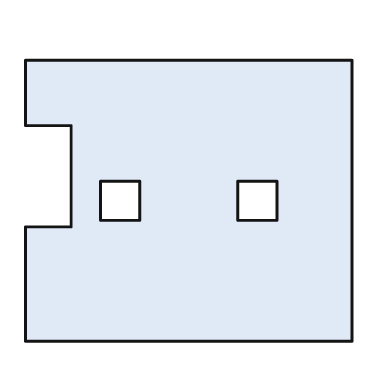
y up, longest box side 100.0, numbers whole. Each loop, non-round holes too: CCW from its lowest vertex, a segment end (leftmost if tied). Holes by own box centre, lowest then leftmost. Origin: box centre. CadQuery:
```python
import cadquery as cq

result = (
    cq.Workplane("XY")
    .moveTo(-50.0, -43.0)
    .lineTo(50.0, -43.0)
    .lineTo(50.0, 43.0)
    .lineTo(-50.0, 43.0)
    .lineTo(-50.0, 23.0)
    .lineTo(-36.0, 23.0)
    .lineTo(-36.0, -8.0)
    .lineTo(-50.0, -8.0)
    .close()
    .moveTo(-27.0, -6.0)
    .lineTo(-15.0, -6.0)
    .lineTo(-15.0, 6.0)
    .lineTo(-27.0, 6.0)
    .close()
    .moveTo(15.0, -6.0)
    .lineTo(27.0, -6.0)
    .lineTo(27.0, 6.0)
    .lineTo(15.0, 6.0)
    .close()
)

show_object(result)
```